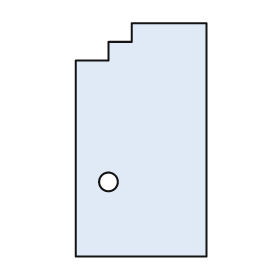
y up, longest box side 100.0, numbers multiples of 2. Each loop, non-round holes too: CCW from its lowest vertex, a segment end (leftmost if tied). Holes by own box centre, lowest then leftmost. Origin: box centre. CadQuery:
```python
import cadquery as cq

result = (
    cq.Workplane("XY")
    .moveTo(-28.0, -50.0)
    .lineTo(28.0, -50.0)
    .lineTo(28.0, 50.0)
    .lineTo(-4.0, 50.0)
    .lineTo(-4.0, 42.0)
    .lineTo(-14.0, 42.0)
    .lineTo(-14.0, 34.0)
    .lineTo(-28.0, 34.0)
    .close()
    .moveTo(-14.0, -18.0)
    .circle(4.0)
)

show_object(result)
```